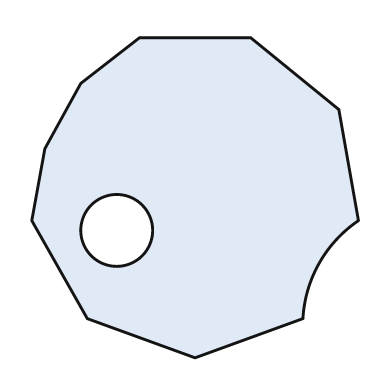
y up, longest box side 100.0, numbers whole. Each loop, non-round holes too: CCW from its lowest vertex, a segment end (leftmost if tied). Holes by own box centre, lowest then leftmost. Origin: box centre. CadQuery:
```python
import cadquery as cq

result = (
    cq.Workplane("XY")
    .moveTo(0.0, -49.0)
    .lineTo(33.0, -37.0)
    .threePointArc((38.0, -20.0), (50.0, -7.0))
    .lineTo(44.0, 27.0)
    .lineTo(17.0, 49.0)
    .lineTo(-17.0, 49.0)
    .lineTo(-35.0, 35.0)
    .lineTo(-46.0, 15.0)
    .lineTo(-50.0, -7.0)
    .lineTo(-33.0, -37.0)
    .close()
    .moveTo(-24.0, -10.0)
    .circle(11.0)
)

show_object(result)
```